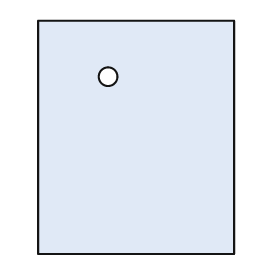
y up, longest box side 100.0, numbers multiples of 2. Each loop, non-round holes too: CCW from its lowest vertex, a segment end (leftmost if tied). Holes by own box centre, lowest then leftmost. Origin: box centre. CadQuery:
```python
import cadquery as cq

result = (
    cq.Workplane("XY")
    .moveTo(-42.0, -50.0)
    .lineTo(42.0, -50.0)
    .lineTo(42.0, 50.0)
    .lineTo(-42.0, 50.0)
    .close()
    .moveTo(-12.0, 26.0)
    .circle(4.0)
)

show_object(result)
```